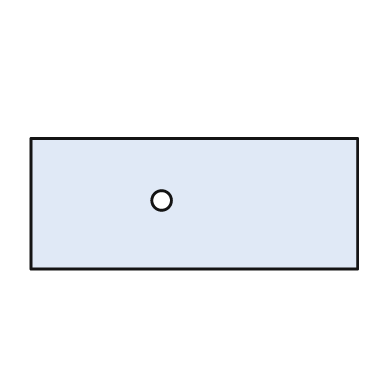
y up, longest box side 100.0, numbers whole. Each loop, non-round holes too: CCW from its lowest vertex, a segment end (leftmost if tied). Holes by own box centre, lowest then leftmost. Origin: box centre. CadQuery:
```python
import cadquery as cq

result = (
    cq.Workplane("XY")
    .moveTo(-50.0, -20.0)
    .lineTo(50.0, -20.0)
    .lineTo(50.0, 20.0)
    .lineTo(-50.0, 20.0)
    .close()
    .moveTo(-10.0, 1.0)
    .circle(3.0)
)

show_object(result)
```